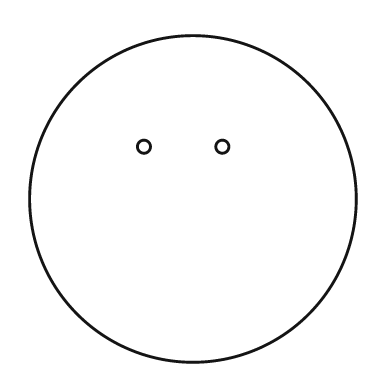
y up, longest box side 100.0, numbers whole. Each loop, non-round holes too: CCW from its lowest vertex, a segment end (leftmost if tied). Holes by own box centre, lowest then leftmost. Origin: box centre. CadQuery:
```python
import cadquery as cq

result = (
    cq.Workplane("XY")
    .moveTo(0.0, 0.0)
    .circle(50.0)
    .moveTo(-15.0, 16.0)
    .circle(2.0)
    .moveTo(9.0, 16.0)
    .circle(2.0)
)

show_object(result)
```